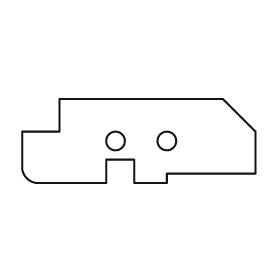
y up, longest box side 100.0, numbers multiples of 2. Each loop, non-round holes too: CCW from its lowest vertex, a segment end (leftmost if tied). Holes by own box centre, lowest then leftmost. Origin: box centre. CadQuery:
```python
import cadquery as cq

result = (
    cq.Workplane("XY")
    .moveTo(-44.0, -18.0)
    .lineTo(-14.0, -18.0)
    .lineTo(-14.0, -8.0)
    .lineTo(-2.0, -8.0)
    .lineTo(-2.0, -18.0)
    .lineTo(12.0, -18.0)
    .lineTo(12.0, -14.0)
    .lineTo(50.0, -14.0)
    .lineTo(50.0, 4.0)
    .lineTo(36.0, 18.0)
    .lineTo(-34.0, 18.0)
    .lineTo(-34.0, 4.0)
    .lineTo(-50.0, 4.0)
    .lineTo(-50.0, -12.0)
    .threePointArc((-48.0, -16.0), (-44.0, -18.0))
    .close()
    .moveTo(-10.0, 0.0)
    .circle(4.0)
    .moveTo(12.0, 0.0)
    .circle(4.0)
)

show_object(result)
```